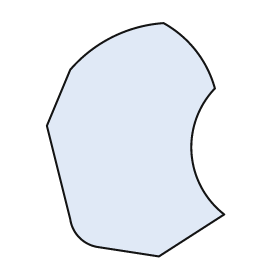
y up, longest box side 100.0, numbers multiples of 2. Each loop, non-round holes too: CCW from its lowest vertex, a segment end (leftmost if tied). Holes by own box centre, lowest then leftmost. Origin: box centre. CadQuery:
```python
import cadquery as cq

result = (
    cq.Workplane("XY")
    .moveTo(10.0, -50.0)
    .lineTo(38.0, -32.0)
    .threePointArc((24.0, -6.0), (34.0, 22.0))
    .threePointArc((26.0, 38.0), (12.0, 50.0))
    .threePointArc((-10.0, 44.0), (-28.0, 30.0))
    .lineTo(-38.0, 6.0)
    .lineTo(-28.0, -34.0)
    .threePointArc((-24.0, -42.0), (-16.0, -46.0))
    .close()
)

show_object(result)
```